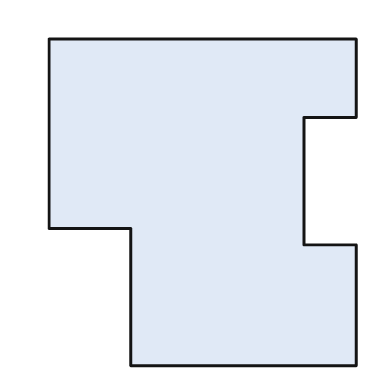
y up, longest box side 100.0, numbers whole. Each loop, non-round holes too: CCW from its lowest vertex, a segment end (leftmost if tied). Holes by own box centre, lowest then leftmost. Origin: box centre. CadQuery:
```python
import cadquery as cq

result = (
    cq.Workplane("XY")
    .moveTo(-22.0, -50.0)
    .lineTo(47.0, -50.0)
    .lineTo(47.0, -13.0)
    .lineTo(31.0, -13.0)
    .lineTo(31.0, 26.0)
    .lineTo(47.0, 26.0)
    .lineTo(47.0, 50.0)
    .lineTo(-47.0, 50.0)
    .lineTo(-47.0, -8.0)
    .lineTo(-22.0, -8.0)
    .close()
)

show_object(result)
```